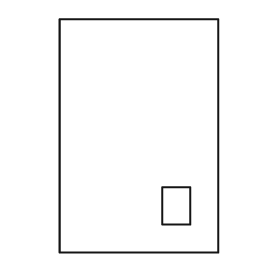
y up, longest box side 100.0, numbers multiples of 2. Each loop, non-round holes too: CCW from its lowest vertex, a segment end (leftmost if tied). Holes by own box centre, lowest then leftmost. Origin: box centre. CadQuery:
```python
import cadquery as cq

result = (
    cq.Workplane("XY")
    .moveTo(-34.0, -50.0)
    .lineTo(34.0, -50.0)
    .lineTo(34.0, 50.0)
    .lineTo(-34.0, 50.0)
    .close()
    .moveTo(10.0, -38.0)
    .lineTo(22.0, -38.0)
    .lineTo(22.0, -22.0)
    .lineTo(10.0, -22.0)
    .close()
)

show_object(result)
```